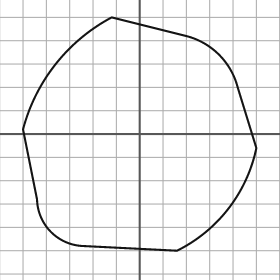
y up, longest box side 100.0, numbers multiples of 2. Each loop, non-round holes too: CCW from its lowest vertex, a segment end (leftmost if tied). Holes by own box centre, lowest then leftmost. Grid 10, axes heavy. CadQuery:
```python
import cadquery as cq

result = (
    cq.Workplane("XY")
    .moveTo(16.0, -50.0)
    .threePointArc((38.0, -32.0), (50.0, -6.0))
    .lineTo(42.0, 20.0)
    .threePointArc((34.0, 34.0), (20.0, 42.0))
    .lineTo(-12.0, 50.0)
    .threePointArc((-36.0, 30.0), (-50.0, 2.0))
    .lineTo(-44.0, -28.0)
    .threePointArc((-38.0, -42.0), (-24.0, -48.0))
    .close()
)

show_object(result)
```